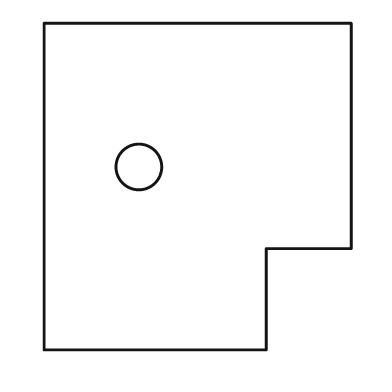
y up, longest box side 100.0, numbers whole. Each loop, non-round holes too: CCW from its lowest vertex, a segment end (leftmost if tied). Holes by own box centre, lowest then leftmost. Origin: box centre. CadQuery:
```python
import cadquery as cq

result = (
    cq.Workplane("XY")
    .moveTo(-47.0, -50.0)
    .lineTo(21.0, -50.0)
    .lineTo(21.0, -19.0)
    .lineTo(47.0, -19.0)
    .lineTo(47.0, 50.0)
    .lineTo(-47.0, 50.0)
    .close()
    .moveTo(-18.0, 6.0)
    .circle(7.0)
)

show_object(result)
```